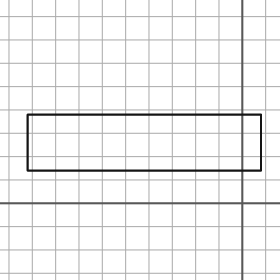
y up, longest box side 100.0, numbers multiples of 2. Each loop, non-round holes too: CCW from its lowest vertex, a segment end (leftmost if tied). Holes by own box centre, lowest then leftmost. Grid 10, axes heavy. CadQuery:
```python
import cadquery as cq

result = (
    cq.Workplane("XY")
    .moveTo(-92.0, 14.0)
    .lineTo(8.0, 14.0)
    .lineTo(8.0, 38.0)
    .lineTo(-92.0, 38.0)
    .close()
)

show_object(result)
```